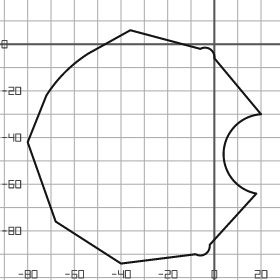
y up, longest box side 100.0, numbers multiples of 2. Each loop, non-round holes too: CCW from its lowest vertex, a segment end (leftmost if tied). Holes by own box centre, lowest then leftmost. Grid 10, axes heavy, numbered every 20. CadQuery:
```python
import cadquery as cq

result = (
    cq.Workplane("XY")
    .moveTo(-40.0, -94.0)
    .lineTo(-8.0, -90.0)
    .threePointArc((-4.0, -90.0), (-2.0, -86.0))
    .lineTo(18.0, -64.0)
    .threePointArc((4.0, -46.0), (20.0, -30.0))
    .lineTo(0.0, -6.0)
    .threePointArc((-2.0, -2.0), (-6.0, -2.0))
    .lineTo(-36.0, 6.0)
    .lineTo(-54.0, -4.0)
    .threePointArc((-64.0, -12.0), (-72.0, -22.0))
    .lineTo(-80.0, -42.0)
    .lineTo(-68.0, -76.0)
    .close()
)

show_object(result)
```